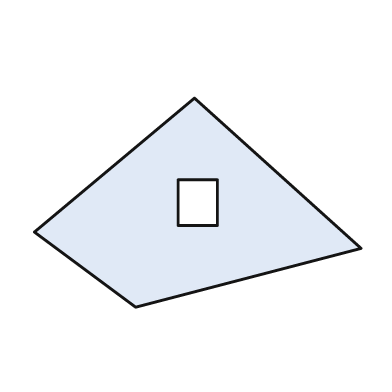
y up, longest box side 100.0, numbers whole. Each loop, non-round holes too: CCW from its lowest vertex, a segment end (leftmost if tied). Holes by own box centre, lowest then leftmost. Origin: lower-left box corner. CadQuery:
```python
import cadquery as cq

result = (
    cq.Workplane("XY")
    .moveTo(31.0, 0.0)
    .lineTo(100.0, 18.0)
    .lineTo(49.0, 64.0)
    .lineTo(0.0, 23.0)
    .close()
    .moveTo(44.0, 25.0)
    .lineTo(56.0, 25.0)
    .lineTo(56.0, 39.0)
    .lineTo(44.0, 39.0)
    .close()
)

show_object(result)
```